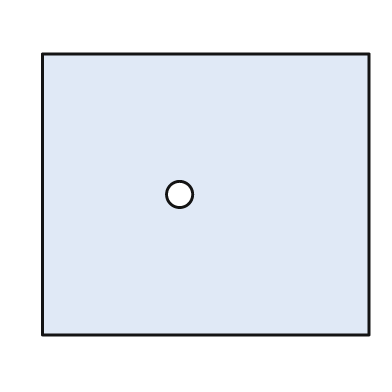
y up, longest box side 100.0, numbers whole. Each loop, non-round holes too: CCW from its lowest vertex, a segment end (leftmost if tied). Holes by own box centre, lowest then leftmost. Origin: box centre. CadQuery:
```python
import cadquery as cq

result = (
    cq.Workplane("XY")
    .moveTo(-50.0, -43.0)
    .lineTo(50.0, -43.0)
    .lineTo(50.0, 43.0)
    .lineTo(-50.0, 43.0)
    .close()
    .moveTo(-8.0, 0.0)
    .circle(4.0)
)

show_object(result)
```